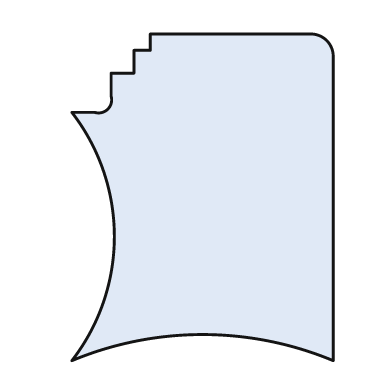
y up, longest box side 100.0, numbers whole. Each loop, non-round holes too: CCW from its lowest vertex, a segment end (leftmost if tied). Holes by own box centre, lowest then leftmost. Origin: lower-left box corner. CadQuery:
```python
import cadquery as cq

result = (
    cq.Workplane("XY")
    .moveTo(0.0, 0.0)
    .threePointArc((40.0, 8.0), (80.0, 0.0))
    .lineTo(80.0, 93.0)
    .threePointArc((78.0, 98.0), (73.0, 100.0))
    .lineTo(24.0, 100.0)
    .lineTo(24.0, 95.0)
    .lineTo(19.0, 95.0)
    .lineTo(19.0, 88.0)
    .lineTo(12.0, 88.0)
    .lineTo(12.0, 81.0)
    .threePointArc((11.0, 77.0), (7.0, 76.0))
    .lineTo(0.0, 76.0)
    .threePointArc((13.0, 38.0), (0.0, 0.0))
    .close()
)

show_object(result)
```